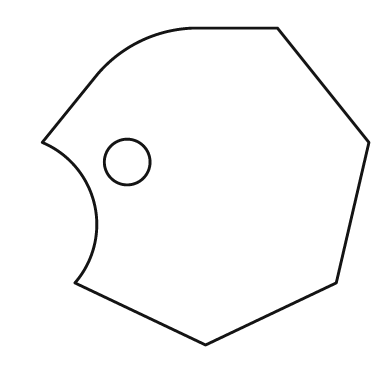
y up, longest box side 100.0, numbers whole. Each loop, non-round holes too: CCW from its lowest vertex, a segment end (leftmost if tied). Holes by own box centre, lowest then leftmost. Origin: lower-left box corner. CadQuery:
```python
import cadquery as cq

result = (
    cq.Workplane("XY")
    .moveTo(50.0, 0.0)
    .lineTo(90.0, 19.0)
    .lineTo(100.0, 62.0)
    .lineTo(72.0, 97.0)
    .lineTo(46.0, 97.0)
    .threePointArc((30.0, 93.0), (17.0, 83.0))
    .lineTo(0.0, 62.0)
    .threePointArc((16.0, 43.0), (10.0, 19.0))
    .close()
    .moveTo(26.0, 56.0)
    .circle(7.0)
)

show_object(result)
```